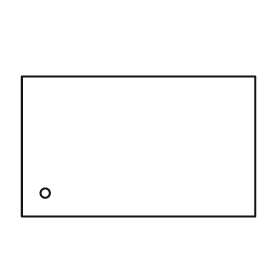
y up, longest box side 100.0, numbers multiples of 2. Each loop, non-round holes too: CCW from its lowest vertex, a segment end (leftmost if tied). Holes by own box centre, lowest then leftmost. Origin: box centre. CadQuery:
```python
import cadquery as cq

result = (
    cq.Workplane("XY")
    .moveTo(-50.0, -30.0)
    .lineTo(50.0, -30.0)
    .lineTo(50.0, 30.0)
    .lineTo(-50.0, 30.0)
    .close()
    .moveTo(-40.0, -20.0)
    .circle(2.0)
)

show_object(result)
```